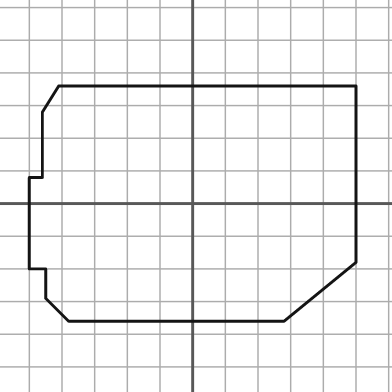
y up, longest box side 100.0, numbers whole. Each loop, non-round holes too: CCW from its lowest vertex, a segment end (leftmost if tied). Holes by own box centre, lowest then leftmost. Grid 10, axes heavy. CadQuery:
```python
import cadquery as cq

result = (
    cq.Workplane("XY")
    .moveTo(-38.0, -36.0)
    .lineTo(28.0, -36.0)
    .lineTo(50.0, -18.0)
    .lineTo(50.0, 36.0)
    .lineTo(-41.0, 36.0)
    .lineTo(-46.0, 28.0)
    .lineTo(-46.0, 8.0)
    .lineTo(-50.0, 8.0)
    .lineTo(-50.0, -20.0)
    .lineTo(-45.0, -20.0)
    .lineTo(-45.0, -29.0)
    .close()
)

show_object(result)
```